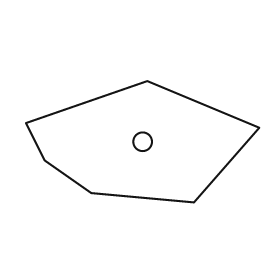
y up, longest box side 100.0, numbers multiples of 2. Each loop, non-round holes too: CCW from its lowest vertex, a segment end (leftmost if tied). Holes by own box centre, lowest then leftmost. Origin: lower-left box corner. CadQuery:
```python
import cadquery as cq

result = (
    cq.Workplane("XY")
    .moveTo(72.0, 0.0)
    .lineTo(100.0, 32.0)
    .lineTo(52.0, 52.0)
    .lineTo(0.0, 34.0)
    .lineTo(8.0, 18.0)
    .lineTo(28.0, 4.0)
    .close()
    .moveTo(50.0, 26.0)
    .circle(4.0)
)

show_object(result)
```